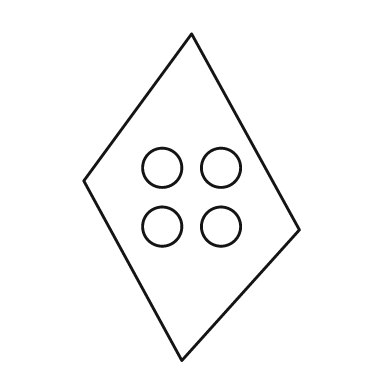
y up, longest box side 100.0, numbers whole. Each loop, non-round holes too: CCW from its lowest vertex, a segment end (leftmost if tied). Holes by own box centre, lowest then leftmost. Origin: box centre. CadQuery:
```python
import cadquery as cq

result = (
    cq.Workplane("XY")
    .moveTo(-3.0, -50.0)
    .lineTo(33.0, -10.0)
    .lineTo(0.0, 50.0)
    .lineTo(-33.0, 5.0)
    .close()
    .moveTo(-9.0, -9.0)
    .circle(6.0)
    .moveTo(9.0, -9.0)
    .circle(6.0)
    .moveTo(-9.0, 9.0)
    .circle(6.0)
    .moveTo(9.0, 9.0)
    .circle(6.0)
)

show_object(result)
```